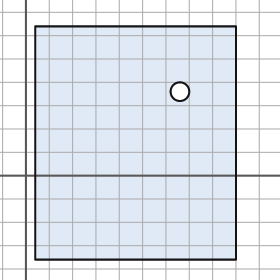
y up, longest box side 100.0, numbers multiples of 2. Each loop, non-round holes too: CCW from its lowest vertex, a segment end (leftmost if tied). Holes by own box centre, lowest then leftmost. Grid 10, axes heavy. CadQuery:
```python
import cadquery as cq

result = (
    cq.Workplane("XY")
    .moveTo(4.0, -36.0)
    .lineTo(90.0, -36.0)
    .lineTo(90.0, 64.0)
    .lineTo(4.0, 64.0)
    .close()
    .moveTo(66.0, 36.0)
    .circle(4.0)
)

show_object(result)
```